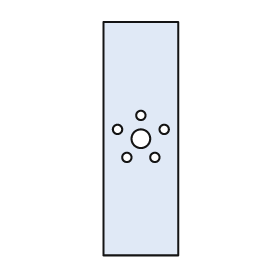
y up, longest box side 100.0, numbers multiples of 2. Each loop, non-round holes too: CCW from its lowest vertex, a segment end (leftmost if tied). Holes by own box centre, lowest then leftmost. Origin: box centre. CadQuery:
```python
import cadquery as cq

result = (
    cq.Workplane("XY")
    .moveTo(-16.0, -50.0)
    .lineTo(16.0, -50.0)
    .lineTo(16.0, 50.0)
    .lineTo(-16.0, 50.0)
    .close()
    .moveTo(-6.0, -8.0)
    .circle(2.0)
    .moveTo(6.0, -8.0)
    .circle(2.0)
    .moveTo(0.0, 0.0)
    .circle(4.0)
    .moveTo(-10.0, 4.0)
    .circle(2.0)
    .moveTo(10.0, 4.0)
    .circle(2.0)
    .moveTo(0.0, 10.0)
    .circle(2.0)
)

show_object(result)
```